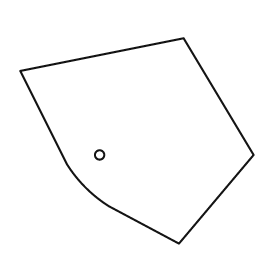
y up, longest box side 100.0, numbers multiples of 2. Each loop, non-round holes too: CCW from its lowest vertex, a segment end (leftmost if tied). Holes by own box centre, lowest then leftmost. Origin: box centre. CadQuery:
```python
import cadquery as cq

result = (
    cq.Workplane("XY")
    .moveTo(18.0, -44.0)
    .lineTo(50.0, -6.0)
    .lineTo(20.0, 44.0)
    .lineTo(-50.0, 30.0)
    .lineTo(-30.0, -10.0)
    .threePointArc((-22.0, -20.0), (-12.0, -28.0))
    .close()
    .moveTo(-16.0, -6.0)
    .circle(2.0)
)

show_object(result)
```